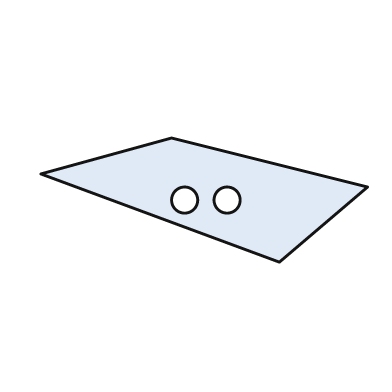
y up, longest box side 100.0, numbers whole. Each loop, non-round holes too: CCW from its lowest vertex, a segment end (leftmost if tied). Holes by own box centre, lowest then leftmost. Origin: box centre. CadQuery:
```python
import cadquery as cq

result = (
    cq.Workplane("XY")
    .moveTo(23.0, -19.0)
    .lineTo(50.0, 4.0)
    .lineTo(-10.0, 19.0)
    .lineTo(-50.0, 8.0)
    .close()
    .moveTo(-6.0, 0.0)
    .circle(4.0)
    .moveTo(7.0, 0.0)
    .circle(4.0)
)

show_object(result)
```